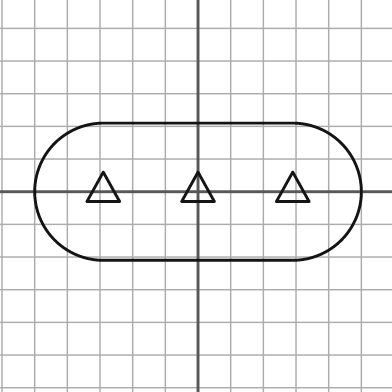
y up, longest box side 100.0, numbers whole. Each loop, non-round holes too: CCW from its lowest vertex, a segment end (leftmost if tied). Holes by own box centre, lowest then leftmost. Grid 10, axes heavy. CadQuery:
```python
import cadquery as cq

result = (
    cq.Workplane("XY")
    .moveTo(-29.0, -21.0)
    .lineTo(29.0, -21.0)
    .threePointArc((50.0, 0.0), (29.0, 21.0))
    .lineTo(-29.0, 21.0)
    .threePointArc((-50.0, 0.0), (-29.0, -21.0))
    .close()
    .moveTo(-34.0, -3.0)
    .lineTo(-24.0, -3.0)
    .lineTo(-29.0, 6.0)
    .close()
    .moveTo(-5.0, -3.0)
    .lineTo(5.0, -3.0)
    .lineTo(0.0, 6.0)
    .close()
    .moveTo(24.0, -3.0)
    .lineTo(34.0, -3.0)
    .lineTo(29.0, 6.0)
    .close()
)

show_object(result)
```